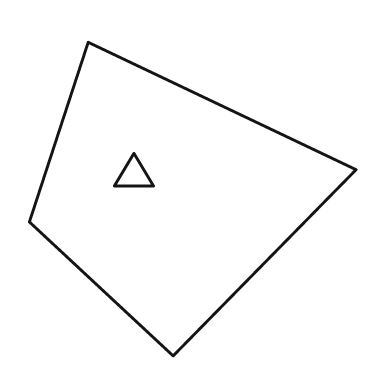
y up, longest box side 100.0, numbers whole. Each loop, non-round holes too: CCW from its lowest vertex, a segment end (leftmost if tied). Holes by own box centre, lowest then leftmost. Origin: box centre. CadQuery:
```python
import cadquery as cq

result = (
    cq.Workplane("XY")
    .moveTo(-6.0, -48.0)
    .lineTo(50.0, 9.0)
    .lineTo(-32.0, 48.0)
    .lineTo(-50.0, -7.0)
    .close()
    .moveTo(-24.0, 4.0)
    .lineTo(-12.0, 4.0)
    .lineTo(-18.0, 14.0)
    .close()
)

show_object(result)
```